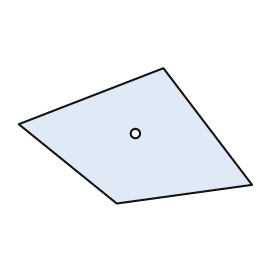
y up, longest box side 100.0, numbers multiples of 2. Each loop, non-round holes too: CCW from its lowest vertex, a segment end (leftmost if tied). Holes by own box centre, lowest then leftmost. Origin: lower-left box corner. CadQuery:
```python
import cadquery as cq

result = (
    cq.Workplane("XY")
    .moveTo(42.0, 0.0)
    .lineTo(100.0, 8.0)
    .lineTo(62.0, 58.0)
    .lineTo(0.0, 34.0)
    .close()
    .moveTo(50.0, 30.0)
    .circle(2.0)
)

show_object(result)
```